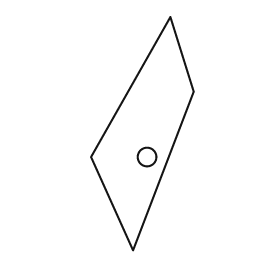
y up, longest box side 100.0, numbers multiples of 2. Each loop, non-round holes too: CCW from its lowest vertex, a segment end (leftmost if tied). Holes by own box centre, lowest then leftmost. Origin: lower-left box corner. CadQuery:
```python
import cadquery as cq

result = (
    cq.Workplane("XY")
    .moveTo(18.0, 0.0)
    .lineTo(44.0, 68.0)
    .lineTo(34.0, 100.0)
    .lineTo(0.0, 40.0)
    .close()
    .moveTo(24.0, 40.0)
    .circle(4.0)
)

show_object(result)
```